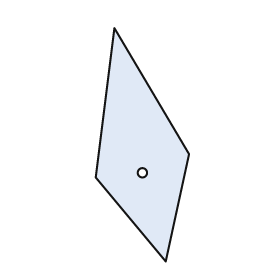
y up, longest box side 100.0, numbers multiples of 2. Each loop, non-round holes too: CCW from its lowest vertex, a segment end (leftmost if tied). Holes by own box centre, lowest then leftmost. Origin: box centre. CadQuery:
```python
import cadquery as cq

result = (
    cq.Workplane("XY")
    .moveTo(10.0, -50.0)
    .lineTo(20.0, -4.0)
    .lineTo(-12.0, 50.0)
    .lineTo(-20.0, -14.0)
    .close()
    .moveTo(0.0, -12.0)
    .circle(2.0)
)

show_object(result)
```